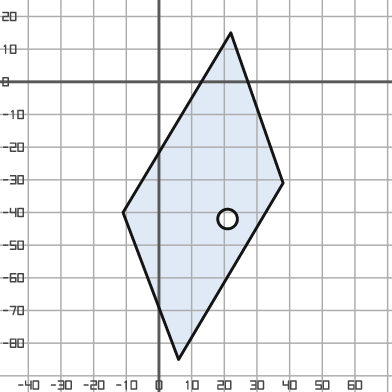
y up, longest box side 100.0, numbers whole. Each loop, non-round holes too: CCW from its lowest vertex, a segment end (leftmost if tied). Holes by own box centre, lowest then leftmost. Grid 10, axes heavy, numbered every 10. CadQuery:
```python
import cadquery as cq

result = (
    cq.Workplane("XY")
    .moveTo(6.0, -85.0)
    .lineTo(38.0, -31.0)
    .lineTo(22.0, 15.0)
    .lineTo(-11.0, -40.0)
    .close()
    .moveTo(21.0, -42.0)
    .circle(3.0)
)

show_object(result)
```